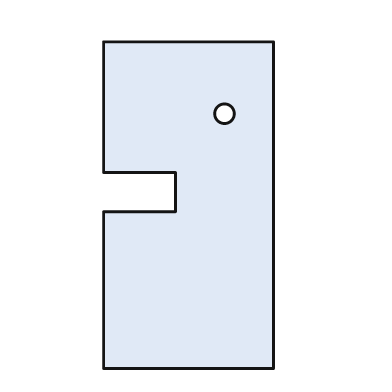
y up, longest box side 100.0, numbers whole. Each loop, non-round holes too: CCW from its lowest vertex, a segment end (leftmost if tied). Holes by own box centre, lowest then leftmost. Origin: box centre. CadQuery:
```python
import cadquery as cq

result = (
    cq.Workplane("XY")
    .moveTo(-26.0, -50.0)
    .lineTo(26.0, -50.0)
    .lineTo(26.0, 50.0)
    .lineTo(-26.0, 50.0)
    .lineTo(-26.0, 10.0)
    .lineTo(-4.0, 10.0)
    .lineTo(-4.0, -2.0)
    .lineTo(-26.0, -2.0)
    .close()
    .moveTo(11.0, 28.0)
    .circle(3.0)
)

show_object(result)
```